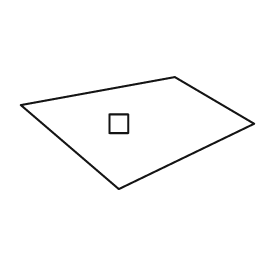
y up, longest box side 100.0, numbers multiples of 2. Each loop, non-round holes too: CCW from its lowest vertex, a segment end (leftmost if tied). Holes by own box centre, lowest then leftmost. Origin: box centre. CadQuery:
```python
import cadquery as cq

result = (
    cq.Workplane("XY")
    .moveTo(-8.0, -24.0)
    .lineTo(50.0, 4.0)
    .lineTo(16.0, 24.0)
    .lineTo(-50.0, 12.0)
    .close()
    .moveTo(-12.0, 0.0)
    .lineTo(-4.0, 0.0)
    .lineTo(-4.0, 8.0)
    .lineTo(-12.0, 8.0)
    .close()
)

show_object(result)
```